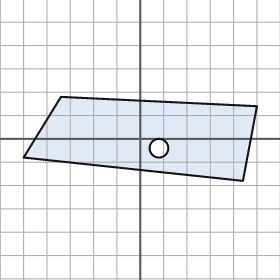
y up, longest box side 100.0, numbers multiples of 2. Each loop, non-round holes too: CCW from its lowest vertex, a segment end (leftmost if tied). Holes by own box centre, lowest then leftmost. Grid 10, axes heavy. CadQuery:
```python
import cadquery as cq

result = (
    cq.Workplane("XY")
    .moveTo(44.0, -18.0)
    .lineTo(50.0, 14.0)
    .lineTo(-34.0, 18.0)
    .lineTo(-50.0, -8.0)
    .close()
    .moveTo(8.0, -4.0)
    .circle(4.0)
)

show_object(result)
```